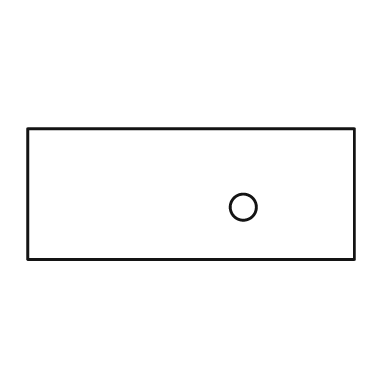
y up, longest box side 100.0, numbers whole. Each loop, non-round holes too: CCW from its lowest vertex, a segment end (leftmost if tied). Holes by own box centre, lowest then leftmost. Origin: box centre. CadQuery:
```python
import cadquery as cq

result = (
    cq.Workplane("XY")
    .moveTo(-50.0, -20.0)
    .lineTo(50.0, -20.0)
    .lineTo(50.0, 20.0)
    .lineTo(-50.0, 20.0)
    .close()
    .moveTo(16.0, -4.0)
    .circle(4.0)
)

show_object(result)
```